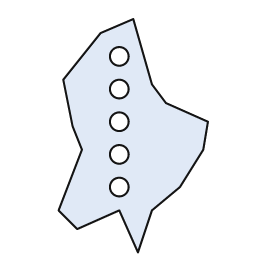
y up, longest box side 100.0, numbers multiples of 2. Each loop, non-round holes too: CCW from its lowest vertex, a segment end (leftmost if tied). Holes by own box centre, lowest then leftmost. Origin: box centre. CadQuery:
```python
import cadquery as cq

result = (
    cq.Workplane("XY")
    .moveTo(2.0, -50.0)
    .lineTo(8.0, -32.0)
    .lineTo(20.0, -22.0)
    .lineTo(30.0, -6.0)
    .lineTo(32.0, 6.0)
    .lineTo(14.0, 14.0)
    .lineTo(8.0, 22.0)
    .lineTo(0.0, 50.0)
    .lineTo(-14.0, 44.0)
    .lineTo(-30.0, 24.0)
    .lineTo(-26.0, 4.0)
    .lineTo(-22.0, -6.0)
    .lineTo(-32.0, -32.0)
    .lineTo(-24.0, -40.0)
    .lineTo(-6.0, -32.0)
    .close()
    .moveTo(-6.0, -22.0)
    .circle(4.0)
    .moveTo(-6.0, -8.0)
    .circle(4.0)
    .moveTo(-6.0, 6.0)
    .circle(4.0)
    .moveTo(-6.0, 20.0)
    .circle(4.0)
    .moveTo(-6.0, 34.0)
    .circle(4.0)
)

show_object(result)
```